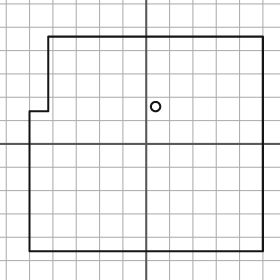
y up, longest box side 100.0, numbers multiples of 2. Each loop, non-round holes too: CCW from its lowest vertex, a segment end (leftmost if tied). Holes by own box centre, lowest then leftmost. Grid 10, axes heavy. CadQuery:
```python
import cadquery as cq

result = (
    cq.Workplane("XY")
    .moveTo(-50.0, -46.0)
    .lineTo(50.0, -46.0)
    .lineTo(50.0, 46.0)
    .lineTo(-42.0, 46.0)
    .lineTo(-42.0, 14.0)
    .lineTo(-50.0, 14.0)
    .close()
    .moveTo(4.0, 16.0)
    .circle(2.0)
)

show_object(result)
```